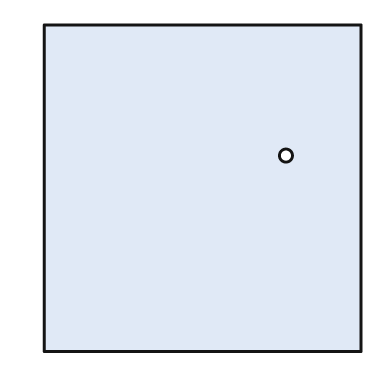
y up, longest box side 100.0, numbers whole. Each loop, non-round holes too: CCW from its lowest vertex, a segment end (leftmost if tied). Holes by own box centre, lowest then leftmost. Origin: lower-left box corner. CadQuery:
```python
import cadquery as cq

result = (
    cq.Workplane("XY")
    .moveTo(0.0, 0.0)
    .lineTo(97.0, 0.0)
    .lineTo(97.0, 100.0)
    .lineTo(0.0, 100.0)
    .close()
    .moveTo(74.0, 60.0)
    .circle(2.0)
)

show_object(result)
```